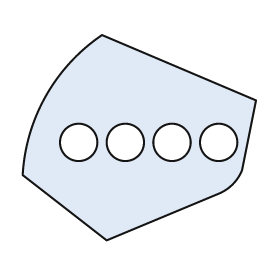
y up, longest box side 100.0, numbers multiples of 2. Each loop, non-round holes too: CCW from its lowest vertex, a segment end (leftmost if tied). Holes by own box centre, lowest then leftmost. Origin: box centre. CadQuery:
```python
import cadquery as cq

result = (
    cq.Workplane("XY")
    .moveTo(-14.0, -44.0)
    .lineTo(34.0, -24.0)
    .threePointArc((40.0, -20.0), (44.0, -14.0))
    .lineTo(50.0, 16.0)
    .lineTo(-16.0, 44.0)
    .threePointArc((-40.0, 18.0), (-50.0, -16.0))
    .close()
    .moveTo(-26.0, -2.0)
    .circle(8.0)
    .moveTo(-6.0, -2.0)
    .circle(8.0)
    .moveTo(14.0, -2.0)
    .circle(8.0)
    .moveTo(34.0, -2.0)
    .circle(8.0)
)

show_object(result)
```